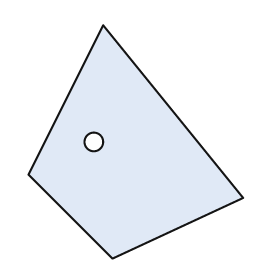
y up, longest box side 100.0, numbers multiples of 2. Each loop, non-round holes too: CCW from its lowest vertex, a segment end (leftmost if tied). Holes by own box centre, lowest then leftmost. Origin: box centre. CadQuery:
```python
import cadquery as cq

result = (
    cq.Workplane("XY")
    .moveTo(-10.0, -50.0)
    .lineTo(46.0, -24.0)
    .lineTo(-14.0, 50.0)
    .lineTo(-46.0, -14.0)
    .close()
    .moveTo(-18.0, 0.0)
    .circle(4.0)
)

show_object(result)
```